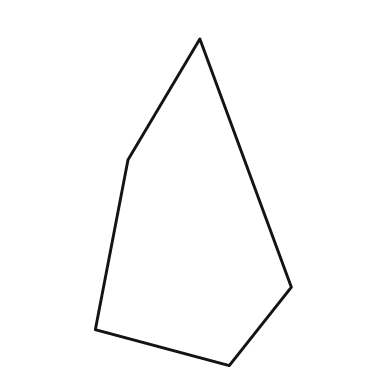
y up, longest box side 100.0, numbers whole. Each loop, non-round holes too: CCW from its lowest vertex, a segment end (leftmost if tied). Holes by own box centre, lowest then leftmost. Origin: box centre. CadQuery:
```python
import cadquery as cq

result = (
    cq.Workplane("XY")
    .moveTo(11.0, -50.0)
    .lineTo(30.0, -26.0)
    .lineTo(2.0, 50.0)
    .lineTo(-20.0, 13.0)
    .lineTo(-30.0, -39.0)
    .close()
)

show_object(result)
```